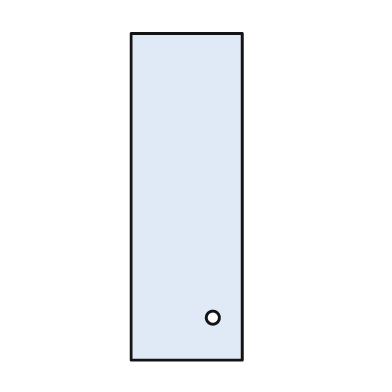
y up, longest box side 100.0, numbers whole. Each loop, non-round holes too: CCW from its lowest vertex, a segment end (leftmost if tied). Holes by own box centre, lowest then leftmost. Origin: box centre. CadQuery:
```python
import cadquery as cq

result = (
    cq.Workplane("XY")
    .moveTo(-17.0, -50.0)
    .lineTo(17.0, -50.0)
    .lineTo(17.0, 50.0)
    .lineTo(-17.0, 50.0)
    .close()
    .moveTo(8.0, -37.0)
    .circle(2.0)
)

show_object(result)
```